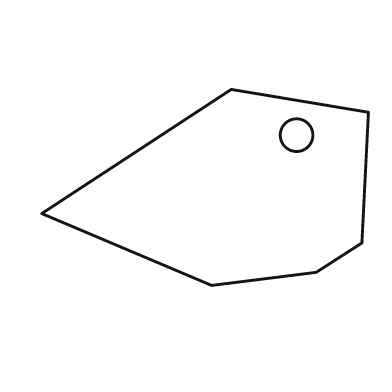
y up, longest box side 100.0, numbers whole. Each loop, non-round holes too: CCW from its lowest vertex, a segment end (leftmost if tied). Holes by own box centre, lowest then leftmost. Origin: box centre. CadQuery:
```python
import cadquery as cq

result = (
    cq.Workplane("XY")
    .moveTo(2.0, -30.0)
    .lineTo(34.0, -26.0)
    .lineTo(48.0, -17.0)
    .lineTo(50.0, 23.0)
    .lineTo(8.0, 30.0)
    .lineTo(-50.0, -8.0)
    .close()
    .moveTo(28.0, 16.0)
    .circle(5.0)
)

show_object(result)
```